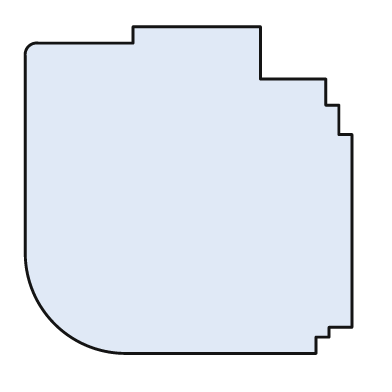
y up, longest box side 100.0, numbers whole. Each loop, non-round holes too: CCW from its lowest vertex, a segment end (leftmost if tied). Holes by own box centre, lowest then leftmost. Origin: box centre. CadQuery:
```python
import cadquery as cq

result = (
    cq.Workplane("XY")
    .moveTo(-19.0, -50.0)
    .lineTo(39.0, -50.0)
    .lineTo(39.0, -45.0)
    .lineTo(43.0, -45.0)
    .lineTo(43.0, -42.0)
    .lineTo(50.0, -42.0)
    .lineTo(50.0, 17.0)
    .lineTo(46.0, 17.0)
    .lineTo(46.0, 26.0)
    .lineTo(42.0, 26.0)
    .lineTo(42.0, 34.0)
    .lineTo(22.0, 34.0)
    .lineTo(22.0, 50.0)
    .lineTo(-17.0, 50.0)
    .lineTo(-17.0, 45.0)
    .lineTo(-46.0, 45.0)
    .threePointArc((-49.0, 44.0), (-50.0, 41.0))
    .lineTo(-50.0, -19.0)
    .threePointArc((-41.0, -41.0), (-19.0, -50.0))
    .close()
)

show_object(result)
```